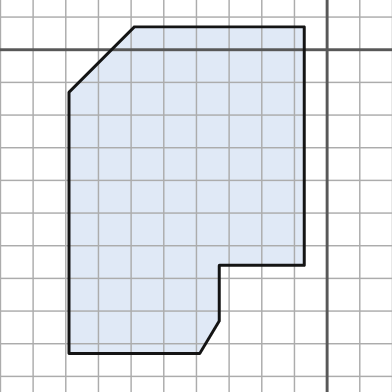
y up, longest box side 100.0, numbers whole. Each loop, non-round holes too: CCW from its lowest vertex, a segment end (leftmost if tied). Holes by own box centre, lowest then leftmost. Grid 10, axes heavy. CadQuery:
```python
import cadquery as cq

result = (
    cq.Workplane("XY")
    .moveTo(-79.0, -93.0)
    .lineTo(-39.0, -93.0)
    .lineTo(-33.0, -83.0)
    .lineTo(-33.0, -66.0)
    .lineTo(-7.0, -66.0)
    .lineTo(-7.0, 7.0)
    .lineTo(-59.0, 7.0)
    .lineTo(-79.0, -13.0)
    .close()
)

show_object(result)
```